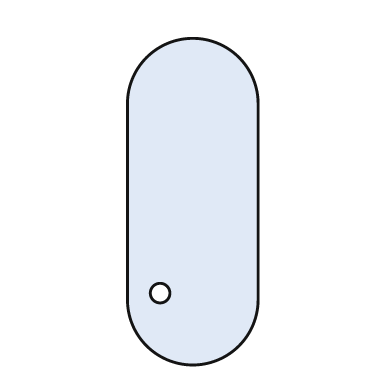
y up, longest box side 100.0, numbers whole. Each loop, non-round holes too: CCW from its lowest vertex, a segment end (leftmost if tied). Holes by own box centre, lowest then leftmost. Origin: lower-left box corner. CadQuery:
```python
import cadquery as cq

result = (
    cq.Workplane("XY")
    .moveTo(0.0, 20.0)
    .threePointArc((20.0, 0.0), (40.0, 20.0))
    .lineTo(40.0, 80.0)
    .threePointArc((20.0, 100.0), (0.0, 80.0))
    .close()
    .moveTo(10.0, 22.0)
    .circle(3.0)
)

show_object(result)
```